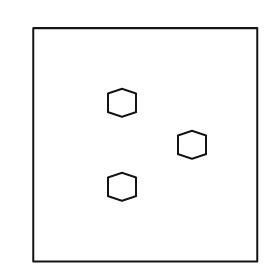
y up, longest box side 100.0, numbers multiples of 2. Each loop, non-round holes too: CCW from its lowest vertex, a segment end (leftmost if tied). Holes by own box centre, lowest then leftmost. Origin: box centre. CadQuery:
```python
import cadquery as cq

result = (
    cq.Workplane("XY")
    .moveTo(-48.0, -50.0)
    .lineTo(48.0, -50.0)
    .lineTo(48.0, 50.0)
    .lineTo(-48.0, 50.0)
    .close()
    .moveTo(-10.0, -24.0)
    .lineTo(-4.0, -22.0)
    .lineTo(-4.0, -14.0)
    .lineTo(-10.0, -12.0)
    .lineTo(-16.0, -14.0)
    .lineTo(-16.0, -22.0)
    .close()
    .moveTo(20.0, -6.0)
    .lineTo(26.0, -4.0)
    .lineTo(26.0, 4.0)
    .lineTo(20.0, 6.0)
    .lineTo(14.0, 4.0)
    .lineTo(14.0, -4.0)
    .close()
    .moveTo(-10.0, 12.0)
    .lineTo(-4.0, 14.0)
    .lineTo(-4.0, 22.0)
    .lineTo(-10.0, 24.0)
    .lineTo(-16.0, 22.0)
    .lineTo(-16.0, 14.0)
    .close()
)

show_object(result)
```